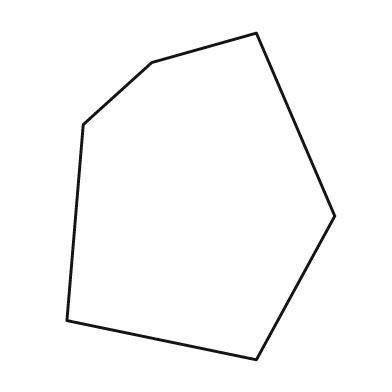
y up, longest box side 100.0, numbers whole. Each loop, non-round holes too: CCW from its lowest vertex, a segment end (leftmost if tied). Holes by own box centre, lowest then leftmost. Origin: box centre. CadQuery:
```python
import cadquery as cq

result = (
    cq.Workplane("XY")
    .moveTo(17.0, -50.0)
    .lineTo(41.0, -6.0)
    .lineTo(17.0, 50.0)
    .lineTo(-15.0, 41.0)
    .lineTo(-36.0, 22.0)
    .lineTo(-41.0, -38.0)
    .close()
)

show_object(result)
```